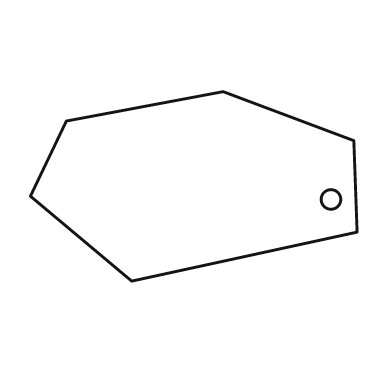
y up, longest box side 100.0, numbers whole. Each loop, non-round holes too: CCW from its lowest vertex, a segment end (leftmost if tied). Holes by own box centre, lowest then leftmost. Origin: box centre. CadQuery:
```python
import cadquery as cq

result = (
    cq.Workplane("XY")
    .moveTo(-19.0, -29.0)
    .lineTo(50.0, -14.0)
    .lineTo(49.0, 14.0)
    .lineTo(9.0, 29.0)
    .lineTo(-39.0, 20.0)
    .lineTo(-50.0, -3.0)
    .close()
    .moveTo(42.0, -4.0)
    .circle(3.0)
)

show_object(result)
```